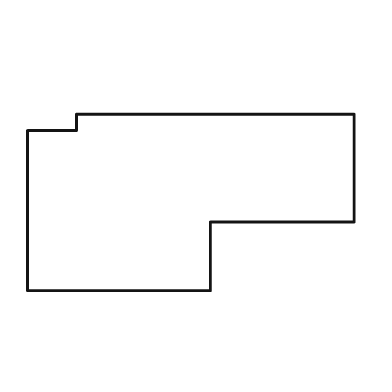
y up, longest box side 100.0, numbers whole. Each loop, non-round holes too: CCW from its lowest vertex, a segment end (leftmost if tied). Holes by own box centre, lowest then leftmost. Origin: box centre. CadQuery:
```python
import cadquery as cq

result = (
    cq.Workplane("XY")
    .moveTo(-50.0, -27.0)
    .lineTo(6.0, -27.0)
    .lineTo(6.0, -6.0)
    .lineTo(50.0, -6.0)
    .lineTo(50.0, 27.0)
    .lineTo(-35.0, 27.0)
    .lineTo(-35.0, 22.0)
    .lineTo(-50.0, 22.0)
    .close()
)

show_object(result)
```